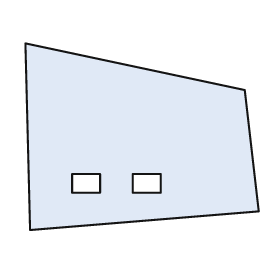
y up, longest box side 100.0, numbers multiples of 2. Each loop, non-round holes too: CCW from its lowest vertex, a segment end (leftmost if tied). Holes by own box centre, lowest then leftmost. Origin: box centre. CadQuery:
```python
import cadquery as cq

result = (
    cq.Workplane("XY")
    .moveTo(-48.0, -40.0)
    .lineTo(50.0, -32.0)
    .lineTo(44.0, 20.0)
    .lineTo(-50.0, 40.0)
    .close()
    .moveTo(-30.0, -24.0)
    .lineTo(-18.0, -24.0)
    .lineTo(-18.0, -16.0)
    .lineTo(-30.0, -16.0)
    .close()
    .moveTo(-4.0, -24.0)
    .lineTo(8.0, -24.0)
    .lineTo(8.0, -16.0)
    .lineTo(-4.0, -16.0)
    .close()
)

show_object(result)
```